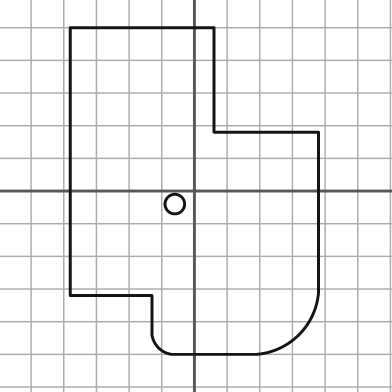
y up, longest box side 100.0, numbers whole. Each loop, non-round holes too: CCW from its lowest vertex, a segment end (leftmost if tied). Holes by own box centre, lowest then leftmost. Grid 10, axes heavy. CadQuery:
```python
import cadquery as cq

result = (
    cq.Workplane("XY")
    .moveTo(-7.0, -50.0)
    .lineTo(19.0, -50.0)
    .threePointArc((32.0, -44.0), (38.0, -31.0))
    .lineTo(38.0, 18.0)
    .lineTo(6.0, 18.0)
    .lineTo(6.0, 50.0)
    .lineTo(-38.0, 50.0)
    .lineTo(-38.0, -32.0)
    .lineTo(-13.0, -32.0)
    .lineTo(-13.0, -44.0)
    .threePointArc((-11.0, -48.0), (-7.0, -50.0))
    .close()
    .moveTo(-6.0, -4.0)
    .circle(3.0)
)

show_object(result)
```